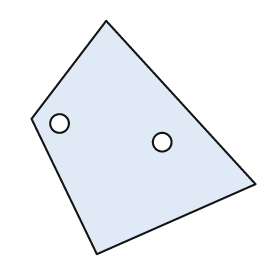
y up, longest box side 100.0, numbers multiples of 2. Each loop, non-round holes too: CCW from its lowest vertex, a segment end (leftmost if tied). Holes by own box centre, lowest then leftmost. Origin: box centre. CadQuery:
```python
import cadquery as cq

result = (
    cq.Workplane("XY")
    .moveTo(-20.0, -50.0)
    .lineTo(48.0, -20.0)
    .lineTo(-16.0, 50.0)
    .lineTo(-48.0, 8.0)
    .close()
    .moveTo(8.0, -2.0)
    .circle(4.0)
    .moveTo(-36.0, 6.0)
    .circle(4.0)
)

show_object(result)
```